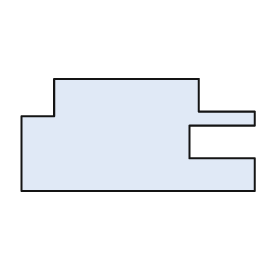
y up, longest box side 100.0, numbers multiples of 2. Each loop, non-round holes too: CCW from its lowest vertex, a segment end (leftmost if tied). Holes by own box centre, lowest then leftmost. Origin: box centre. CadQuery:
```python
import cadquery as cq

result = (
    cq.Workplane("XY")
    .moveTo(-50.0, -24.0)
    .lineTo(50.0, -24.0)
    .lineTo(50.0, -10.0)
    .lineTo(22.0, -10.0)
    .lineTo(22.0, 4.0)
    .lineTo(50.0, 4.0)
    .lineTo(50.0, 10.0)
    .lineTo(26.0, 10.0)
    .lineTo(26.0, 24.0)
    .lineTo(-36.0, 24.0)
    .lineTo(-36.0, 8.0)
    .lineTo(-50.0, 8.0)
    .close()
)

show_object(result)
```